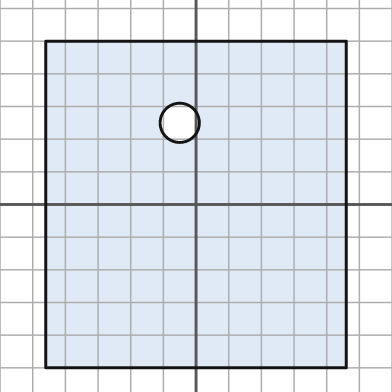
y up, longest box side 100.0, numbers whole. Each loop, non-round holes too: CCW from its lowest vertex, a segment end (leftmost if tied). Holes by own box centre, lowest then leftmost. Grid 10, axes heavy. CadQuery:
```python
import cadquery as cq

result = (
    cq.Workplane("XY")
    .moveTo(-46.0, -50.0)
    .lineTo(46.0, -50.0)
    .lineTo(46.0, 50.0)
    .lineTo(-46.0, 50.0)
    .close()
    .moveTo(-5.0, 25.0)
    .circle(6.0)
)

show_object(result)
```